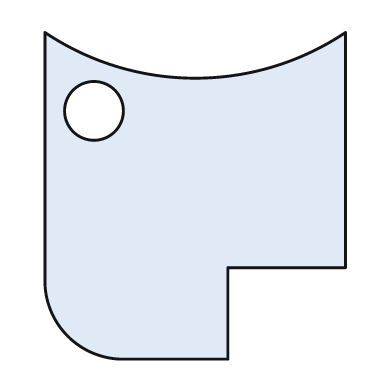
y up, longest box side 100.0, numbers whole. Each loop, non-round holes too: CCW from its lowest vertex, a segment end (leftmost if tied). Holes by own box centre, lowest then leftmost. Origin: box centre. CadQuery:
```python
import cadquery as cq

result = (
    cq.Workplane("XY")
    .moveTo(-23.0, -50.0)
    .lineTo(10.0, -50.0)
    .lineTo(10.0, -22.0)
    .lineTo(46.0, -22.0)
    .lineTo(46.0, 50.0)
    .threePointArc((0.0, 36.0), (-46.0, 50.0))
    .lineTo(-46.0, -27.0)
    .threePointArc((-39.0, -43.0), (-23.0, -50.0))
    .close()
    .moveTo(-31.0, 26.0)
    .circle(9.0)
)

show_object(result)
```